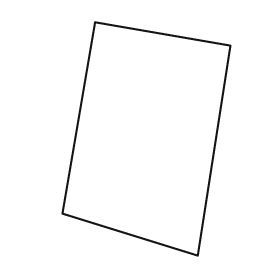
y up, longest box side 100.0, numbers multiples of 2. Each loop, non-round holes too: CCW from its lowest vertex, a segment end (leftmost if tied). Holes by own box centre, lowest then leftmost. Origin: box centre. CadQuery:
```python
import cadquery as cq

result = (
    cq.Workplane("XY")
    .moveTo(22.0, -50.0)
    .lineTo(36.0, 40.0)
    .lineTo(-22.0, 50.0)
    .lineTo(-36.0, -32.0)
    .close()
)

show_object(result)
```